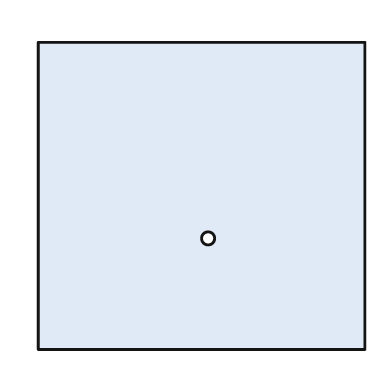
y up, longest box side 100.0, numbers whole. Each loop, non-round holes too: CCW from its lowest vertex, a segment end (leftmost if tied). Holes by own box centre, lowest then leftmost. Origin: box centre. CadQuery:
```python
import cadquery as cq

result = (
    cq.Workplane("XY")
    .moveTo(-50.0, -47.0)
    .lineTo(50.0, -47.0)
    .lineTo(50.0, 47.0)
    .lineTo(-50.0, 47.0)
    .close()
    .moveTo(2.0, -13.0)
    .circle(2.0)
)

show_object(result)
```